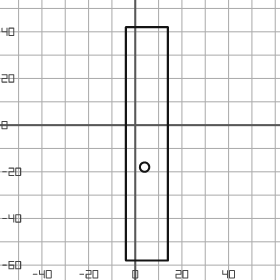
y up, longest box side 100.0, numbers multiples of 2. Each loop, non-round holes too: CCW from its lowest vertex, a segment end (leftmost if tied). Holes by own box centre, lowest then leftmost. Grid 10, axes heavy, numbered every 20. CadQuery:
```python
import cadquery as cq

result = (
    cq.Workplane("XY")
    .moveTo(-4.0, -58.0)
    .lineTo(14.0, -58.0)
    .lineTo(14.0, 42.0)
    .lineTo(-4.0, 42.0)
    .close()
    .moveTo(4.0, -18.0)
    .circle(2.0)
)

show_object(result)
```